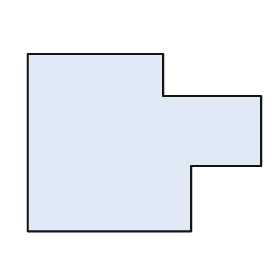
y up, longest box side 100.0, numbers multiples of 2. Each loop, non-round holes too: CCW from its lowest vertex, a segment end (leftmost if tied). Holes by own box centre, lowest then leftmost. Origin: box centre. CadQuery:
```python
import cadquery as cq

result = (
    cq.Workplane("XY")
    .moveTo(-50.0, -38.0)
    .lineTo(20.0, -38.0)
    .lineTo(20.0, -10.0)
    .lineTo(50.0, -10.0)
    .lineTo(50.0, 20.0)
    .lineTo(8.0, 20.0)
    .lineTo(8.0, 38.0)
    .lineTo(-50.0, 38.0)
    .close()
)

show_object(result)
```